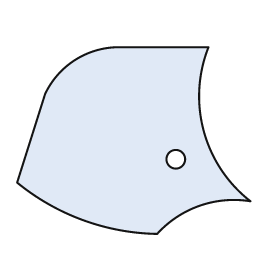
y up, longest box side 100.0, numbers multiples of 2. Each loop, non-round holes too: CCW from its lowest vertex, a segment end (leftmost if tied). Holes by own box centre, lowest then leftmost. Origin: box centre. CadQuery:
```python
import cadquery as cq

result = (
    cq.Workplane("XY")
    .moveTo(10.0, -40.0)
    .threePointArc((28.0, -28.0), (50.0, -26.0))
    .threePointArc((30.0, 4.0), (32.0, 40.0))
    .lineTo(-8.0, 40.0)
    .threePointArc((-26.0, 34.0), (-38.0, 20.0))
    .lineTo(-50.0, -18.0)
    .threePointArc((-22.0, -34.0), (10.0, -40.0))
    .close()
    .moveTo(18.0, -8.0)
    .circle(4.0)
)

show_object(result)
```